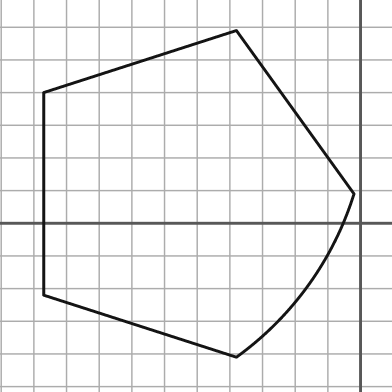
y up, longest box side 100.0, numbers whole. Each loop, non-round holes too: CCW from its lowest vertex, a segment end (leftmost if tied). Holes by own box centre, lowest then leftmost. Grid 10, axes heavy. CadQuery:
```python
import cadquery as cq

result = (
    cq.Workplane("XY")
    .moveTo(-38.0, -41.0)
    .threePointArc((-16.0, -19.0), (-2.0, 9.0))
    .lineTo(-38.0, 59.0)
    .lineTo(-97.0, 40.0)
    .lineTo(-97.0, -22.0)
    .close()
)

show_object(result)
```